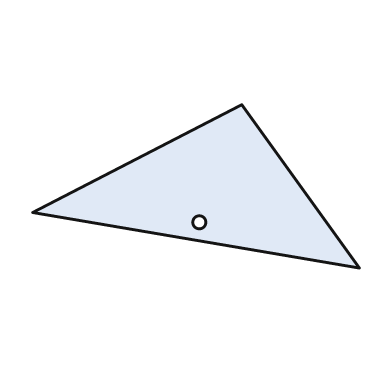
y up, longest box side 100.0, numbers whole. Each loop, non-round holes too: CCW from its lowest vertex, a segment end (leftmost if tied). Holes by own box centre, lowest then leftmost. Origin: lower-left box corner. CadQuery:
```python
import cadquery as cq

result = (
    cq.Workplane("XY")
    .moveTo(100.0, 0.0)
    .lineTo(64.0, 50.0)
    .lineTo(0.0, 17.0)
    .close()
    .moveTo(51.0, 14.0)
    .circle(2.0)
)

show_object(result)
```